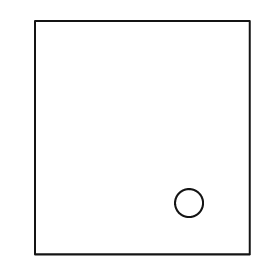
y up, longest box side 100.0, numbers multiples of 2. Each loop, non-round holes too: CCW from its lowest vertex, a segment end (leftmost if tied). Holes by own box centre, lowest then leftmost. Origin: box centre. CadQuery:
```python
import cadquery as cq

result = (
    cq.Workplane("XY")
    .moveTo(-46.0, -50.0)
    .lineTo(46.0, -50.0)
    .lineTo(46.0, 50.0)
    .lineTo(-46.0, 50.0)
    .close()
    .moveTo(20.0, -28.0)
    .circle(6.0)
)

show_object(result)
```